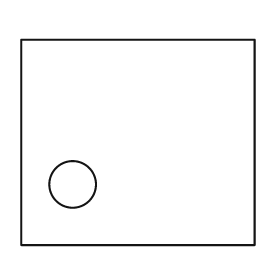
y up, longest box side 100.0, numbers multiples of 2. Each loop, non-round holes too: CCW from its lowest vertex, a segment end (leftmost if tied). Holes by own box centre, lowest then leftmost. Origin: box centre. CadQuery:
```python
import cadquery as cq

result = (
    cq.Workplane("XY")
    .moveTo(-50.0, -44.0)
    .lineTo(50.0, -44.0)
    .lineTo(50.0, 44.0)
    .lineTo(-50.0, 44.0)
    .close()
    .moveTo(-28.0, -18.0)
    .circle(10.0)
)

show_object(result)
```